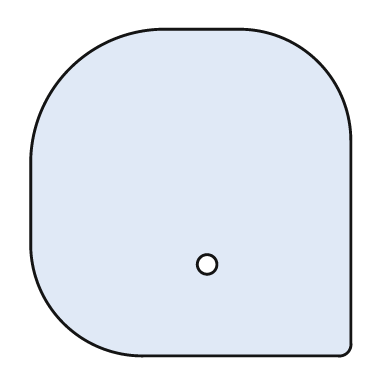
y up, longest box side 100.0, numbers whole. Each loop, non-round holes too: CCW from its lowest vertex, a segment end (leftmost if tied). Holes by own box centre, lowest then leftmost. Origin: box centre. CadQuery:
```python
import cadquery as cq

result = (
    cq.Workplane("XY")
    .moveTo(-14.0, -50.0)
    .lineTo(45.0, -50.0)
    .threePointArc((48.0, -49.0), (49.0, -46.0))
    .lineTo(49.0, 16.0)
    .threePointArc((39.0, 40.0), (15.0, 50.0))
    .lineTo(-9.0, 50.0)
    .threePointArc((-37.0, 38.0), (-49.0, 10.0))
    .lineTo(-49.0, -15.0)
    .threePointArc((-39.0, -40.0), (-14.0, -50.0))
    .close()
    .moveTo(5.0, -22.0)
    .circle(3.0)
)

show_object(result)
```